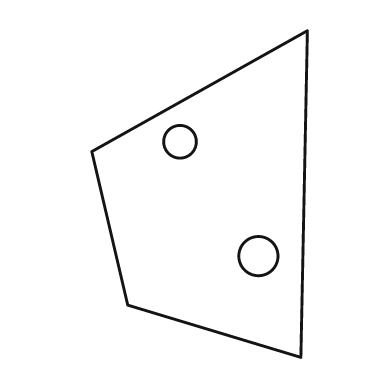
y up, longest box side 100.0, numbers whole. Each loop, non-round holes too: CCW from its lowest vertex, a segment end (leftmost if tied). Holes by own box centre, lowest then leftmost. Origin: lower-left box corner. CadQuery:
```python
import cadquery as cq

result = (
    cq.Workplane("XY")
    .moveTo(64.0, 0.0)
    .lineTo(66.0, 100.0)
    .lineTo(0.0, 63.0)
    .lineTo(11.0, 16.0)
    .close()
    .moveTo(51.0, 31.0)
    .circle(6.0)
    .moveTo(27.0, 66.0)
    .circle(5.0)
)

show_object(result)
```